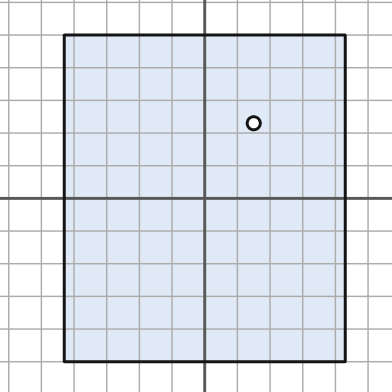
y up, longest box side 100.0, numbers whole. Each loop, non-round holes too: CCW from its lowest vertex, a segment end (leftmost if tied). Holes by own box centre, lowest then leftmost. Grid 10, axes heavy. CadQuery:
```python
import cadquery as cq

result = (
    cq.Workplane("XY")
    .moveTo(-43.0, -50.0)
    .lineTo(43.0, -50.0)
    .lineTo(43.0, 50.0)
    .lineTo(-43.0, 50.0)
    .close()
    .moveTo(15.0, 23.0)
    .circle(2.0)
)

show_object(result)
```